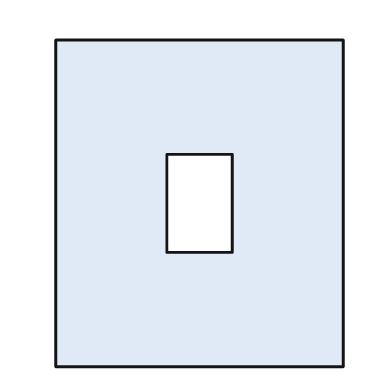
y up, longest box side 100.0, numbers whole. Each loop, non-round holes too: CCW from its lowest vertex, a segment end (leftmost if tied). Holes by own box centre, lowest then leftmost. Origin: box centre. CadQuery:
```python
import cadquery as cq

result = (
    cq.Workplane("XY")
    .moveTo(-44.0, -50.0)
    .lineTo(44.0, -50.0)
    .lineTo(44.0, 50.0)
    .lineTo(-44.0, 50.0)
    .close()
    .moveTo(-10.0, -15.0)
    .lineTo(10.0, -15.0)
    .lineTo(10.0, 15.0)
    .lineTo(-10.0, 15.0)
    .close()
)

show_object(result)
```